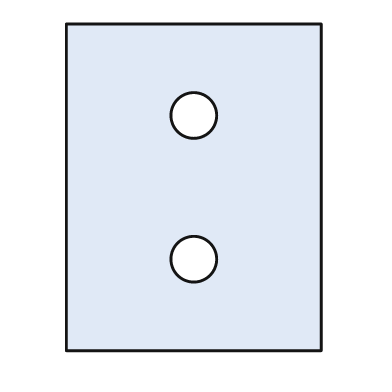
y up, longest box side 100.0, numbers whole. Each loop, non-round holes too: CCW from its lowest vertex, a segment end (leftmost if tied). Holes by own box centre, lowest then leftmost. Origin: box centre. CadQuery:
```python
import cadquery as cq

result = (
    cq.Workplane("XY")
    .moveTo(-39.0, -50.0)
    .lineTo(39.0, -50.0)
    .lineTo(39.0, 50.0)
    .lineTo(-39.0, 50.0)
    .close()
    .moveTo(0.0, -22.0)
    .circle(7.0)
    .moveTo(0.0, 22.0)
    .circle(7.0)
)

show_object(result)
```